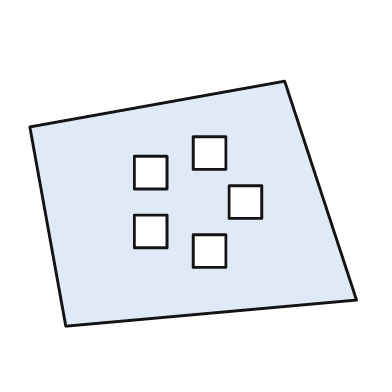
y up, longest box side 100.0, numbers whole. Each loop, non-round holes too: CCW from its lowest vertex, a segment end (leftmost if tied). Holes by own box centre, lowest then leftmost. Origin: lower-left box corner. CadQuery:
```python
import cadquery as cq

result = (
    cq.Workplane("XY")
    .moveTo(11.0, 0.0)
    .lineTo(100.0, 8.0)
    .lineTo(78.0, 75.0)
    .lineTo(0.0, 61.0)
    .close()
    .moveTo(50.0, 18.0)
    .lineTo(60.0, 18.0)
    .lineTo(60.0, 28.0)
    .lineTo(50.0, 28.0)
    .close()
    .moveTo(32.0, 24.0)
    .lineTo(42.0, 24.0)
    .lineTo(42.0, 34.0)
    .lineTo(32.0, 34.0)
    .close()
    .moveTo(61.0, 33.0)
    .lineTo(71.0, 33.0)
    .lineTo(71.0, 43.0)
    .lineTo(61.0, 43.0)
    .close()
    .moveTo(32.0, 42.0)
    .lineTo(42.0, 42.0)
    .lineTo(42.0, 52.0)
    .lineTo(32.0, 52.0)
    .close()
    .moveTo(50.0, 48.0)
    .lineTo(60.0, 48.0)
    .lineTo(60.0, 58.0)
    .lineTo(50.0, 58.0)
    .close()
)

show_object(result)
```